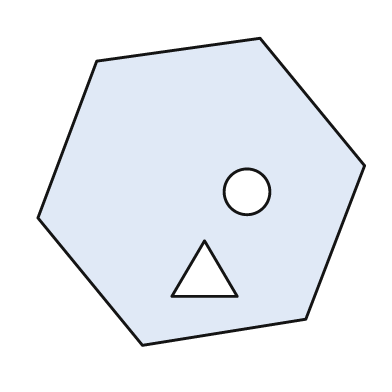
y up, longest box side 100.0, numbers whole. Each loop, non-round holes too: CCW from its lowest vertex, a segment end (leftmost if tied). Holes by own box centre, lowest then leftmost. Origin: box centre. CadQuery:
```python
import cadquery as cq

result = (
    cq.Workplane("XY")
    .moveTo(-18.0, -47.0)
    .lineTo(32.0, -39.0)
    .lineTo(50.0, 8.0)
    .lineTo(18.0, 47.0)
    .lineTo(-32.0, 40.0)
    .lineTo(-50.0, -8.0)
    .close()
    .moveTo(-9.0, -32.0)
    .lineTo(11.0, -32.0)
    .lineTo(1.0, -15.0)
    .close()
    .moveTo(14.0, 0.0)
    .circle(7.0)
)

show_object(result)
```